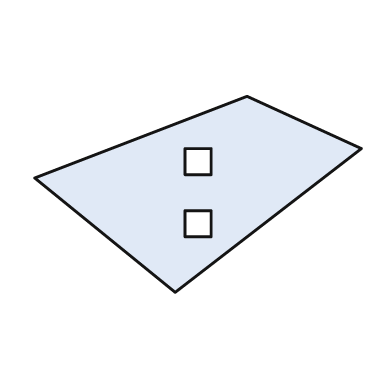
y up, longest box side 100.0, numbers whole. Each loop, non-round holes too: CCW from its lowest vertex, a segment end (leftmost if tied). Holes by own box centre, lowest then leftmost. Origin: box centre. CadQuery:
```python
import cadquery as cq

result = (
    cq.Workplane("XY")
    .moveTo(-7.0, -30.0)
    .lineTo(50.0, 14.0)
    .lineTo(15.0, 30.0)
    .lineTo(-50.0, 5.0)
    .close()
    .moveTo(-4.0, -13.0)
    .lineTo(4.0, -13.0)
    .lineTo(4.0, -5.0)
    .lineTo(-4.0, -5.0)
    .close()
    .moveTo(-4.0, 6.0)
    .lineTo(4.0, 6.0)
    .lineTo(4.0, 14.0)
    .lineTo(-4.0, 14.0)
    .close()
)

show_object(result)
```